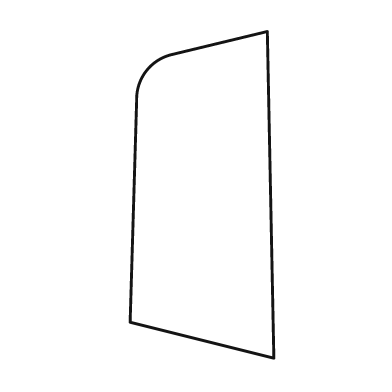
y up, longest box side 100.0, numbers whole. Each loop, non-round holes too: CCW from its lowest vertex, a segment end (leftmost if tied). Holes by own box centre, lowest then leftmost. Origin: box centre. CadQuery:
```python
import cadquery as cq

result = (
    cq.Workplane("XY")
    .moveTo(22.0, -50.0)
    .lineTo(20.0, 50.0)
    .lineTo(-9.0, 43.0)
    .threePointArc((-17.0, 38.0), (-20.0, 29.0))
    .lineTo(-22.0, -39.0)
    .close()
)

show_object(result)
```